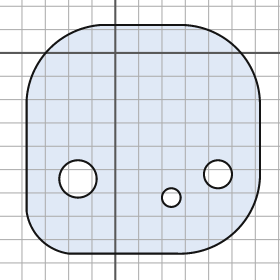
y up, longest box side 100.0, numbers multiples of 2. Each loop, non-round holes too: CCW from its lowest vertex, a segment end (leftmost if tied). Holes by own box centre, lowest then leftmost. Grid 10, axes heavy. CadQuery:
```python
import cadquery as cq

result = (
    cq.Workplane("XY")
    .moveTo(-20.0, -86.0)
    .lineTo(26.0, -86.0)
    .threePointArc((52.0, -76.0), (62.0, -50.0))
    .lineTo(62.0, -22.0)
    .threePointArc((52.0, 2.0), (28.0, 12.0))
    .lineTo(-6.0, 12.0)
    .threePointArc((-28.0, 2.0), (-38.0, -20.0))
    .lineTo(-38.0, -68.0)
    .threePointArc((-32.0, -80.0), (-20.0, -86.0))
    .close()
    .moveTo(24.0, -62.0)
    .circle(4.0)
    .moveTo(-16.0, -54.0)
    .circle(8.0)
    .moveTo(44.0, -52.0)
    .circle(6.0)
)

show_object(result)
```